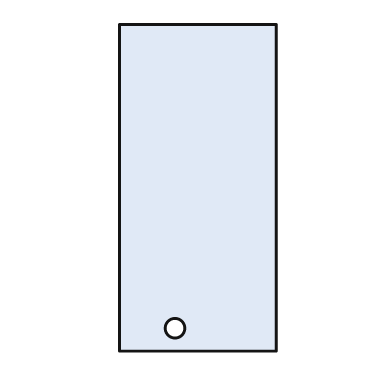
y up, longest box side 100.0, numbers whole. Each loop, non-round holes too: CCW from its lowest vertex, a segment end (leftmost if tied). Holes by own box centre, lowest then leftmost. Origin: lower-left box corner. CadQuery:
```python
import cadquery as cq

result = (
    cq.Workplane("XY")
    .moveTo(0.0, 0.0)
    .lineTo(48.0, 0.0)
    .lineTo(48.0, 100.0)
    .lineTo(0.0, 100.0)
    .close()
    .moveTo(17.0, 7.0)
    .circle(3.0)
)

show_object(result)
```